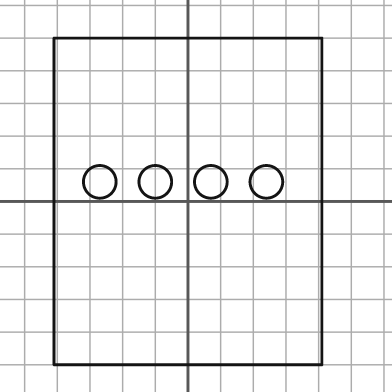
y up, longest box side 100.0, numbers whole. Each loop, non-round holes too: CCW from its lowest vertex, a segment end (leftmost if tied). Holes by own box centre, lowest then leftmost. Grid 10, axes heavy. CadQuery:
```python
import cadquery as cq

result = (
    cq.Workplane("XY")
    .moveTo(-41.0, -50.0)
    .lineTo(41.0, -50.0)
    .lineTo(41.0, 50.0)
    .lineTo(-41.0, 50.0)
    .close()
    .moveTo(-27.0, 6.0)
    .circle(5.0)
    .moveTo(-10.0, 6.0)
    .circle(5.0)
    .moveTo(7.0, 6.0)
    .circle(5.0)
    .moveTo(24.0, 6.0)
    .circle(5.0)
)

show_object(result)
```